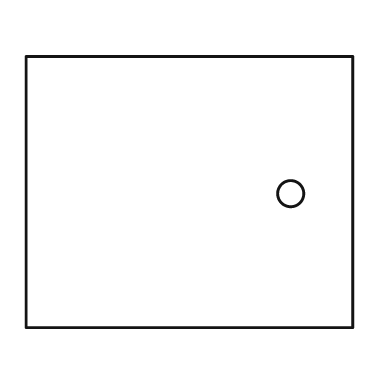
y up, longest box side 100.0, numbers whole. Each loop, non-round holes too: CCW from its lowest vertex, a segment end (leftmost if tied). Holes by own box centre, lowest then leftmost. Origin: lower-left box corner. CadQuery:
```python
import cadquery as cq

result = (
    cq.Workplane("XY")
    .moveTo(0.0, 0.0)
    .lineTo(100.0, 0.0)
    .lineTo(100.0, 83.0)
    .lineTo(0.0, 83.0)
    .close()
    .moveTo(81.0, 41.0)
    .circle(4.0)
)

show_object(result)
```